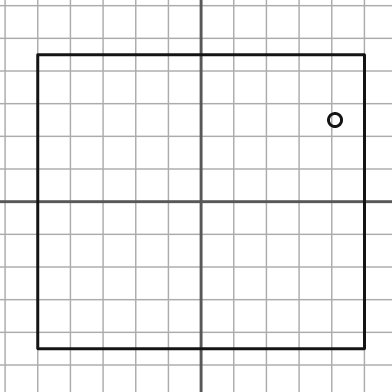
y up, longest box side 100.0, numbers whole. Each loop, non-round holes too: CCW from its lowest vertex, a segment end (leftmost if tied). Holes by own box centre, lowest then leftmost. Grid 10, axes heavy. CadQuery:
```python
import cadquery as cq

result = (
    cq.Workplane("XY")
    .moveTo(-50.0, -45.0)
    .lineTo(50.0, -45.0)
    .lineTo(50.0, 45.0)
    .lineTo(-50.0, 45.0)
    .close()
    .moveTo(41.0, 25.0)
    .circle(2.0)
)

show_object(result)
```